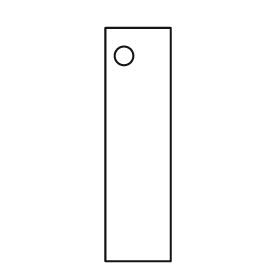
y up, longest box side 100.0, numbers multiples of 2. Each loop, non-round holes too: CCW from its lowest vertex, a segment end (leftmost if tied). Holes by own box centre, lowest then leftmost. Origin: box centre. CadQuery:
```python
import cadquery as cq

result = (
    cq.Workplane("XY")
    .moveTo(-14.0, -50.0)
    .lineTo(14.0, -50.0)
    .lineTo(14.0, 50.0)
    .lineTo(-14.0, 50.0)
    .close()
    .moveTo(-6.0, 38.0)
    .circle(4.0)
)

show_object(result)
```